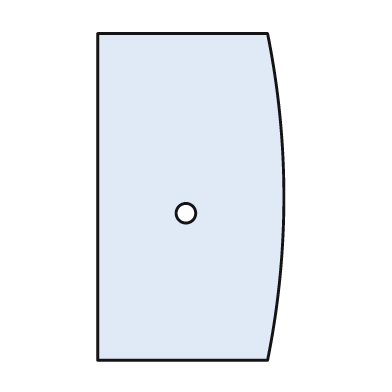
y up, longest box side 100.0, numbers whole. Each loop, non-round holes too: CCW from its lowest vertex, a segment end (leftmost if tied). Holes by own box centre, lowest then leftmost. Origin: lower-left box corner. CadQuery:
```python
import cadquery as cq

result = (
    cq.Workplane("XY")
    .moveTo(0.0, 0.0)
    .lineTo(52.0, 0.0)
    .threePointArc((57.0, 50.0), (52.0, 100.0))
    .lineTo(0.0, 100.0)
    .close()
    .moveTo(27.0, 45.0)
    .circle(3.0)
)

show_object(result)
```